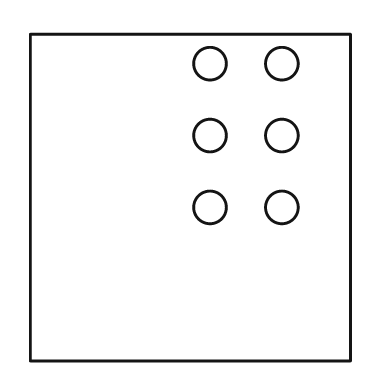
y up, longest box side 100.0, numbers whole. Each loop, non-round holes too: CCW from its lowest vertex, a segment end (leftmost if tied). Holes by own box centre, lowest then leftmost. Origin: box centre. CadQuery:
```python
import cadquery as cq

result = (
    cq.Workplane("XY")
    .moveTo(-49.0, -50.0)
    .lineTo(49.0, -50.0)
    .lineTo(49.0, 50.0)
    .lineTo(-49.0, 50.0)
    .close()
    .moveTo(6.0, -3.0)
    .circle(5.0)
    .moveTo(28.0, -3.0)
    .circle(5.0)
    .moveTo(6.0, 19.0)
    .circle(5.0)
    .moveTo(28.0, 19.0)
    .circle(5.0)
    .moveTo(6.0, 41.0)
    .circle(5.0)
    .moveTo(28.0, 41.0)
    .circle(5.0)
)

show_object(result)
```